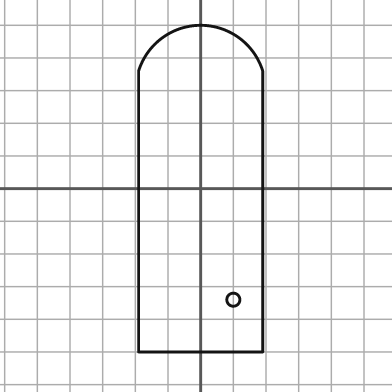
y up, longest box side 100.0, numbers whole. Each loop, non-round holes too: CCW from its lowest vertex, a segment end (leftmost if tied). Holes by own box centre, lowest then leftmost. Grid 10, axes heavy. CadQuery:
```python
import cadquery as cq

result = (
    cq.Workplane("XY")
    .moveTo(-19.0, -50.0)
    .lineTo(19.0, -50.0)
    .lineTo(19.0, 36.0)
    .threePointArc((0.0, 50.0), (-19.0, 36.0))
    .close()
    .moveTo(10.0, -34.0)
    .circle(2.0)
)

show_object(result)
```